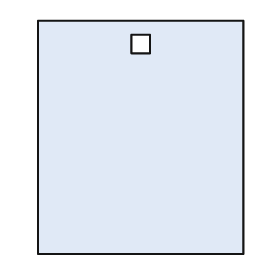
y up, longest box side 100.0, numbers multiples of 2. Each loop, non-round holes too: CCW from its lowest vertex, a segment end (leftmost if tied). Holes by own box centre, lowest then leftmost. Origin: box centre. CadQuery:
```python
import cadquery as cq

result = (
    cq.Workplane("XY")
    .moveTo(-44.0, -50.0)
    .lineTo(44.0, -50.0)
    .lineTo(44.0, 50.0)
    .lineTo(-44.0, 50.0)
    .close()
    .moveTo(-4.0, 36.0)
    .lineTo(4.0, 36.0)
    .lineTo(4.0, 44.0)
    .lineTo(-4.0, 44.0)
    .close()
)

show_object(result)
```